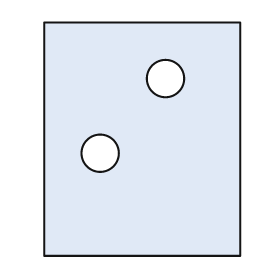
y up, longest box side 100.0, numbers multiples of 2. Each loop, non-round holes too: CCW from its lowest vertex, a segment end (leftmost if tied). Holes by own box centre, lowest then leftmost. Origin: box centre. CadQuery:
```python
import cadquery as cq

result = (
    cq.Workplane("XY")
    .moveTo(-42.0, -50.0)
    .lineTo(42.0, -50.0)
    .lineTo(42.0, 50.0)
    .lineTo(-42.0, 50.0)
    .close()
    .moveTo(-18.0, -6.0)
    .circle(8.0)
    .moveTo(10.0, 26.0)
    .circle(8.0)
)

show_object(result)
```